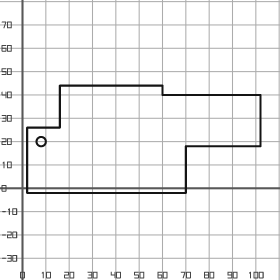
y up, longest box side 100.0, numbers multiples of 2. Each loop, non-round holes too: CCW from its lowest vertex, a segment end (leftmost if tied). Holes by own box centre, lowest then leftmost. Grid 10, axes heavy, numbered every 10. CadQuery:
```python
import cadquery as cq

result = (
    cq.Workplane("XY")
    .moveTo(2.0, -2.0)
    .lineTo(70.0, -2.0)
    .lineTo(70.0, 18.0)
    .lineTo(102.0, 18.0)
    .lineTo(102.0, 40.0)
    .lineTo(60.0, 40.0)
    .lineTo(60.0, 44.0)
    .lineTo(16.0, 44.0)
    .lineTo(16.0, 26.0)
    .lineTo(2.0, 26.0)
    .close()
    .moveTo(8.0, 20.0)
    .circle(2.0)
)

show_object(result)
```